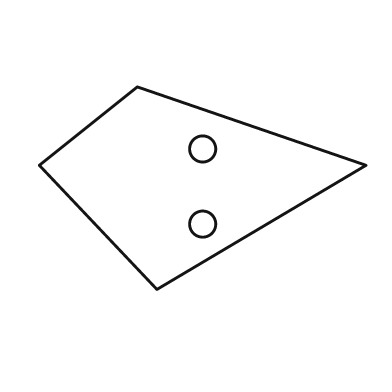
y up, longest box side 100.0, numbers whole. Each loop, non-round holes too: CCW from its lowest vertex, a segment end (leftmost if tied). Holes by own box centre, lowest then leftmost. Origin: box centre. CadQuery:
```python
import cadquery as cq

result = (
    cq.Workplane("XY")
    .moveTo(-14.0, -31.0)
    .lineTo(50.0, 7.0)
    .lineTo(-20.0, 31.0)
    .lineTo(-50.0, 7.0)
    .close()
    .moveTo(0.0, -11.0)
    .circle(4.0)
    .moveTo(0.0, 12.0)
    .circle(4.0)
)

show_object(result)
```